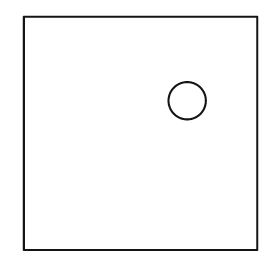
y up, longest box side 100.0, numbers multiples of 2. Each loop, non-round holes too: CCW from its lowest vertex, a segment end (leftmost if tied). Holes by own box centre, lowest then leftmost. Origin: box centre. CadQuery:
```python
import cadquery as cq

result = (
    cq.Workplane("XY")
    .moveTo(-50.0, -50.0)
    .lineTo(50.0, -50.0)
    .lineTo(50.0, 50.0)
    .lineTo(-50.0, 50.0)
    .close()
    .moveTo(20.0, 14.0)
    .circle(8.0)
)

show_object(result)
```